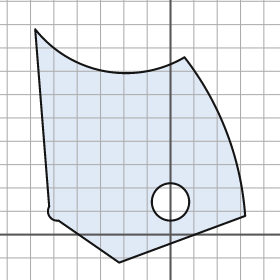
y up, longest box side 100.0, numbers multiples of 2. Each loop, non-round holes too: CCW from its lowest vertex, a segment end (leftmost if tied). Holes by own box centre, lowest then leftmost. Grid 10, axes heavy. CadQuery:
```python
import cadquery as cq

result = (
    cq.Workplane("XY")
    .moveTo(-22.0, -12.0)
    .lineTo(32.0, 8.0)
    .threePointArc((24.0, 44.0), (6.0, 76.0))
    .threePointArc((-28.0, 70.0), (-58.0, 88.0))
    .lineTo(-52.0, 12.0)
    .threePointArc((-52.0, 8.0), (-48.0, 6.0))
    .close()
    .moveTo(0.0, 14.0)
    .circle(8.0)
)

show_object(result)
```